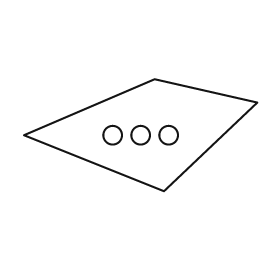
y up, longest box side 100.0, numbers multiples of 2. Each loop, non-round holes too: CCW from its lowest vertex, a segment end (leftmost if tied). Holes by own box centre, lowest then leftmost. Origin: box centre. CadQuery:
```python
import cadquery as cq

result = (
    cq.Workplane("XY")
    .moveTo(10.0, -24.0)
    .lineTo(50.0, 14.0)
    .lineTo(6.0, 24.0)
    .lineTo(-50.0, 0.0)
    .close()
    .moveTo(-12.0, 0.0)
    .circle(4.0)
    .moveTo(0.0, 0.0)
    .circle(4.0)
    .moveTo(12.0, 0.0)
    .circle(4.0)
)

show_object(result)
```